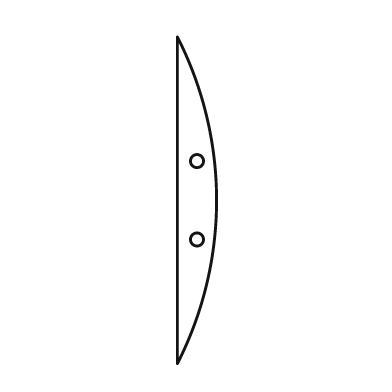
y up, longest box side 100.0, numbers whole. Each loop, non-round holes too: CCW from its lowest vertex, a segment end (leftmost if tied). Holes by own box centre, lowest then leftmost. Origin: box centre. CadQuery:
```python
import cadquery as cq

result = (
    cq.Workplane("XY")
    .moveTo(-6.0, -50.0)
    .threePointArc((6.0, 0.0), (-6.0, 50.0))
    .close()
    .moveTo(0.0, -12.0)
    .circle(2.0)
    .moveTo(0.0, 12.0)
    .circle(2.0)
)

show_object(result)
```